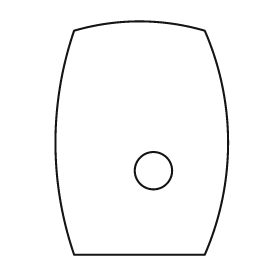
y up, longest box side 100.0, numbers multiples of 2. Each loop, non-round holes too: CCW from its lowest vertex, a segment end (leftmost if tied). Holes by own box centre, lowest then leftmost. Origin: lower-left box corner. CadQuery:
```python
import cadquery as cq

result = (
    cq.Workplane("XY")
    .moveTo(8.0, 0.0)
    .lineTo(64.0, 0.0)
    .threePointArc((74.0, 48.0), (64.0, 96.0))
    .threePointArc((36.0, 100.0), (8.0, 96.0))
    .threePointArc((0.0, 48.0), (8.0, 0.0))
    .close()
    .moveTo(42.0, 36.0)
    .circle(8.0)
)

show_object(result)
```